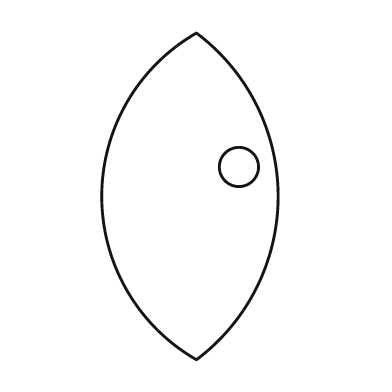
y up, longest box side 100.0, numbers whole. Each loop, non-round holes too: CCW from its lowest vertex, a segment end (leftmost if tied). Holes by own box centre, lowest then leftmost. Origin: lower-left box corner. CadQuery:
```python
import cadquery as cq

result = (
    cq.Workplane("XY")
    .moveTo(29.0, 0.0)
    .threePointArc((54.0, 50.0), (29.0, 100.0))
    .threePointArc((0.0, 50.0), (29.0, 0.0))
    .close()
    .moveTo(42.0, 59.0)
    .circle(6.0)
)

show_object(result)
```